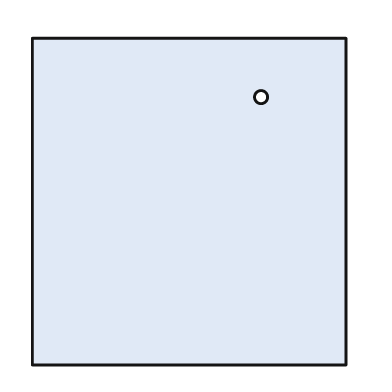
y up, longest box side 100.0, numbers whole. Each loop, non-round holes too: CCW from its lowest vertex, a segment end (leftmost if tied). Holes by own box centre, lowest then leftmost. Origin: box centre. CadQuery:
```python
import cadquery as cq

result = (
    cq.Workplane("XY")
    .moveTo(-48.0, -50.0)
    .lineTo(48.0, -50.0)
    .lineTo(48.0, 50.0)
    .lineTo(-48.0, 50.0)
    .close()
    .moveTo(22.0, 32.0)
    .circle(2.0)
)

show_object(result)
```